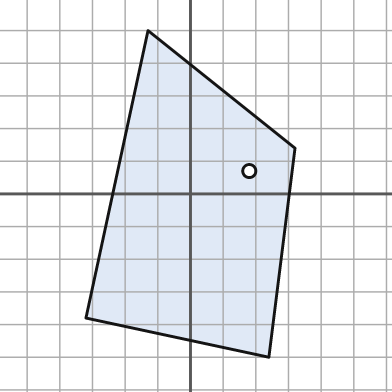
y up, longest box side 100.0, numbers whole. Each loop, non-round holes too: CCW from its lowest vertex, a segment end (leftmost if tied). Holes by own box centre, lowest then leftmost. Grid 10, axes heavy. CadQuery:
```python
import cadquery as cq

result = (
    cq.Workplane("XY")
    .moveTo(24.0, -50.0)
    .lineTo(32.0, 14.0)
    .lineTo(-13.0, 50.0)
    .lineTo(-32.0, -38.0)
    .close()
    .moveTo(18.0, 7.0)
    .circle(2.0)
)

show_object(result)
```